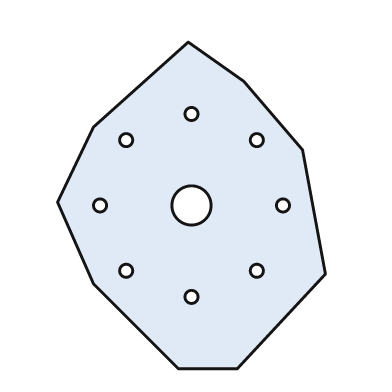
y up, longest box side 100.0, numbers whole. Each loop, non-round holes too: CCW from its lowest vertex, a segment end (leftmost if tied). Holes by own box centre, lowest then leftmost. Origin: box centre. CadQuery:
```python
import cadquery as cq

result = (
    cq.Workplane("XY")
    .moveTo(-4.0, -50.0)
    .lineTo(14.0, -50.0)
    .lineTo(41.0, -21.0)
    .lineTo(34.0, 17.0)
    .lineTo(16.0, 38.0)
    .lineTo(-1.0, 50.0)
    .lineTo(-30.0, 24.0)
    .lineTo(-41.0, 1.0)
    .lineTo(-30.0, -24.0)
    .close()
    .moveTo(0.0, -28.0)
    .circle(2.0)
    .moveTo(-20.0, -20.0)
    .circle(2.0)
    .moveTo(20.0, -20.0)
    .circle(2.0)
    .moveTo(-28.0, 0.0)
    .circle(2.0)
    .moveTo(0.0, 0.0)
    .circle(6.0)
    .moveTo(28.0, 0.0)
    .circle(2.0)
    .moveTo(-20.0, 20.0)
    .circle(2.0)
    .moveTo(20.0, 20.0)
    .circle(2.0)
    .moveTo(0.0, 28.0)
    .circle(2.0)
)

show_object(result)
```